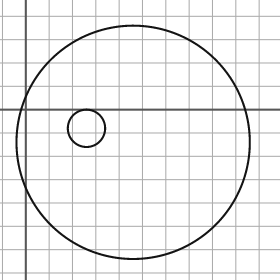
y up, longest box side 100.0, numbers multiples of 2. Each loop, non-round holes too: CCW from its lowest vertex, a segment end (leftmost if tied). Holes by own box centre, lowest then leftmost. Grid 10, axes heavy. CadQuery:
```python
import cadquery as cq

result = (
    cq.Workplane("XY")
    .moveTo(46.0, -14.0)
    .circle(50.0)
    .moveTo(26.0, -8.0)
    .circle(8.0)
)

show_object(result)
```